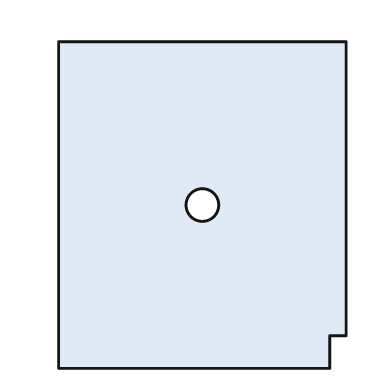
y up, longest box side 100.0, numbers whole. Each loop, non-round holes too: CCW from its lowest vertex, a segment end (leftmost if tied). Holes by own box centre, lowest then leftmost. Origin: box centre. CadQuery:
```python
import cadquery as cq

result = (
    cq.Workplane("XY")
    .moveTo(-44.0, -50.0)
    .lineTo(39.0, -50.0)
    .lineTo(39.0, -40.0)
    .lineTo(44.0, -40.0)
    .lineTo(44.0, 50.0)
    .lineTo(-44.0, 50.0)
    .close()
    .moveTo(0.0, 0.0)
    .circle(5.0)
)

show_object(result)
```